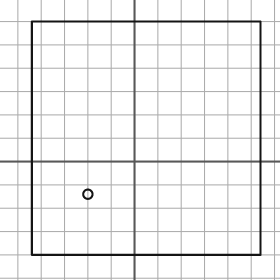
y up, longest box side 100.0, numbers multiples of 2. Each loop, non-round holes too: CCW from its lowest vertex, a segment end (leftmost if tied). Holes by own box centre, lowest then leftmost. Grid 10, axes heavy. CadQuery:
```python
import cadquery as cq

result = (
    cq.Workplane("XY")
    .moveTo(-44.0, -40.0)
    .lineTo(54.0, -40.0)
    .lineTo(54.0, 60.0)
    .lineTo(-44.0, 60.0)
    .close()
    .moveTo(-20.0, -14.0)
    .circle(2.0)
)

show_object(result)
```